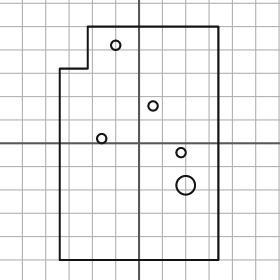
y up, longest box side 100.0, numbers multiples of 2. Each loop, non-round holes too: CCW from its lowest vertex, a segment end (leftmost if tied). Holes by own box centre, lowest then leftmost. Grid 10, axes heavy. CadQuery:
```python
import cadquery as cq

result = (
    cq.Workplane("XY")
    .moveTo(-34.0, -50.0)
    .lineTo(34.0, -50.0)
    .lineTo(34.0, 50.0)
    .lineTo(-22.0, 50.0)
    .lineTo(-22.0, 32.0)
    .lineTo(-34.0, 32.0)
    .close()
    .moveTo(20.0, -18.0)
    .circle(4.0)
    .moveTo(18.0, -4.0)
    .circle(2.0)
    .moveTo(-16.0, 2.0)
    .circle(2.0)
    .moveTo(6.0, 16.0)
    .circle(2.0)
    .moveTo(-10.0, 42.0)
    .circle(2.0)
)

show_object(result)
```